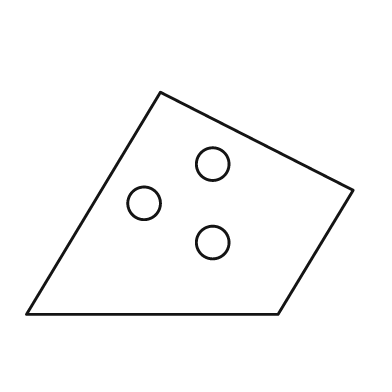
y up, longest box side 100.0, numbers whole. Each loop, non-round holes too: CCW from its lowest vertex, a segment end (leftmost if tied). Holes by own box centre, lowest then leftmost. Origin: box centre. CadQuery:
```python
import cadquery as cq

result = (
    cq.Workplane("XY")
    .moveTo(-50.0, -34.0)
    .lineTo(27.0, -34.0)
    .lineTo(50.0, 4.0)
    .lineTo(-9.0, 34.0)
    .close()
    .moveTo(7.0, -12.0)
    .circle(5.0)
    .moveTo(-14.0, 0.0)
    .circle(5.0)
    .moveTo(7.0, 12.0)
    .circle(5.0)
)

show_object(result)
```